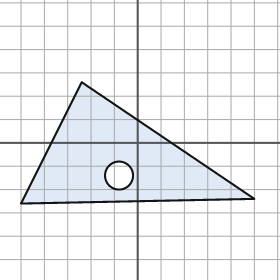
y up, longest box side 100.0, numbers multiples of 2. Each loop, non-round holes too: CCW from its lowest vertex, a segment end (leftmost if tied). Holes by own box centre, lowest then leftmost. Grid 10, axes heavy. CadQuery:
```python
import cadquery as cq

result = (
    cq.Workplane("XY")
    .moveTo(-50.0, -26.0)
    .lineTo(50.0, -24.0)
    .lineTo(-24.0, 26.0)
    .close()
    .moveTo(-8.0, -14.0)
    .circle(6.0)
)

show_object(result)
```